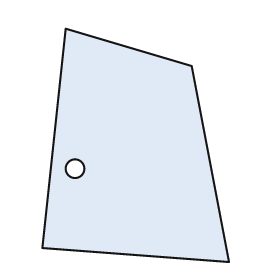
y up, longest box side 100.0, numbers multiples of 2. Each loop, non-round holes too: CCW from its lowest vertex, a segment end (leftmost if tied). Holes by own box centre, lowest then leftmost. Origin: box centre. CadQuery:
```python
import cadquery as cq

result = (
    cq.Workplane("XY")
    .moveTo(40.0, -50.0)
    .lineTo(24.0, 34.0)
    .lineTo(-30.0, 50.0)
    .lineTo(-40.0, -44.0)
    .close()
    .moveTo(-26.0, -10.0)
    .circle(4.0)
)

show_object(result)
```